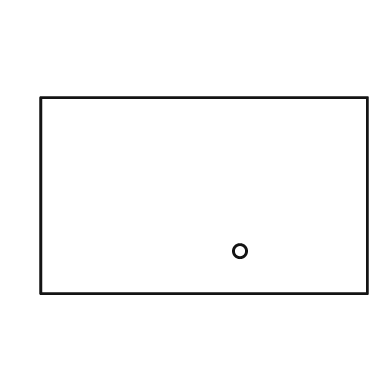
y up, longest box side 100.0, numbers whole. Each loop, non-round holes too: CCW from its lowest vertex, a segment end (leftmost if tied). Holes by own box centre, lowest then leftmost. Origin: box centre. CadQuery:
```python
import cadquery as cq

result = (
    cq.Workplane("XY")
    .moveTo(-50.0, -30.0)
    .lineTo(50.0, -30.0)
    .lineTo(50.0, 30.0)
    .lineTo(-50.0, 30.0)
    .close()
    .moveTo(11.0, -17.0)
    .circle(2.0)
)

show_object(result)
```